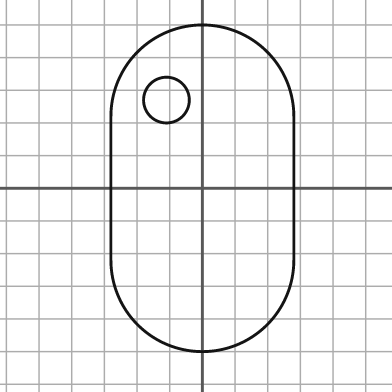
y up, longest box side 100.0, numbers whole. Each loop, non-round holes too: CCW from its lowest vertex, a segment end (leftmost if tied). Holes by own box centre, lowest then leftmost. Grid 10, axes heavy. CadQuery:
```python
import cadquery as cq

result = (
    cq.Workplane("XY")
    .moveTo(-28.0, -22.0)
    .threePointArc((0.0, -50.0), (28.0, -22.0))
    .lineTo(28.0, 22.0)
    .threePointArc((0.0, 50.0), (-28.0, 22.0))
    .close()
    .moveTo(-11.0, 27.0)
    .circle(7.0)
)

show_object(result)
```